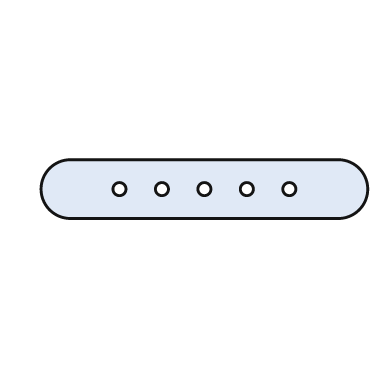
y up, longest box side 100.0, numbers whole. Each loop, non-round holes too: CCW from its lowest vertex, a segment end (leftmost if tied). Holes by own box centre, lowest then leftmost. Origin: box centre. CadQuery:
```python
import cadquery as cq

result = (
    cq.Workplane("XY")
    .moveTo(-41.0, -9.0)
    .lineTo(41.0, -9.0)
    .threePointArc((50.0, 0.0), (41.0, 9.0))
    .lineTo(-41.0, 9.0)
    .threePointArc((-50.0, 0.0), (-41.0, -9.0))
    .close()
    .moveTo(-26.0, 0.0)
    .circle(2.0)
    .moveTo(-13.0, 0.0)
    .circle(2.0)
    .moveTo(0.0, 0.0)
    .circle(2.0)
    .moveTo(13.0, 0.0)
    .circle(2.0)
    .moveTo(26.0, 0.0)
    .circle(2.0)
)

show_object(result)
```